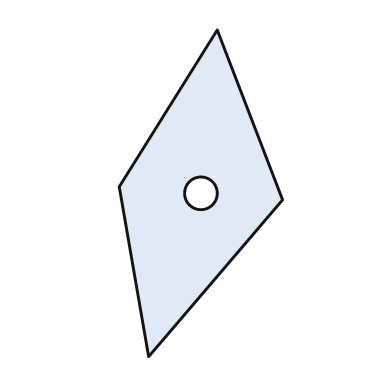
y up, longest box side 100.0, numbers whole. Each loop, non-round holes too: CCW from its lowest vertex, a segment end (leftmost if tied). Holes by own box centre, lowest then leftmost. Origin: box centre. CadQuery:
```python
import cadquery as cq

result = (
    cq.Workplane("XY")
    .moveTo(-16.0, -50.0)
    .lineTo(25.0, -2.0)
    .lineTo(5.0, 50.0)
    .lineTo(-25.0, 2.0)
    .close()
    .moveTo(0.0, 0.0)
    .circle(5.0)
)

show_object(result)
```